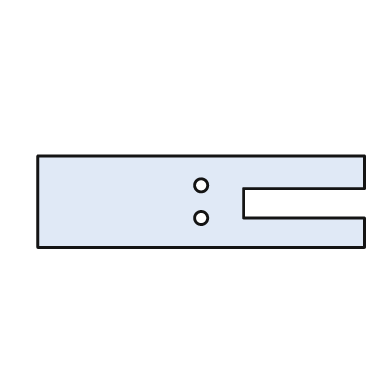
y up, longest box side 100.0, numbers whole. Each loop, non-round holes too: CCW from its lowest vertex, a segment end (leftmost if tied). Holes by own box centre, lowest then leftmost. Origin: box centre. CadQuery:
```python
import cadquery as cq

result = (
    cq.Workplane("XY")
    .moveTo(-50.0, -14.0)
    .lineTo(50.0, -14.0)
    .lineTo(50.0, -5.0)
    .lineTo(13.0, -5.0)
    .lineTo(13.0, 4.0)
    .lineTo(50.0, 4.0)
    .lineTo(50.0, 14.0)
    .lineTo(-50.0, 14.0)
    .close()
    .moveTo(0.0, -5.0)
    .circle(2.0)
    .moveTo(0.0, 5.0)
    .circle(2.0)
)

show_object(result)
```